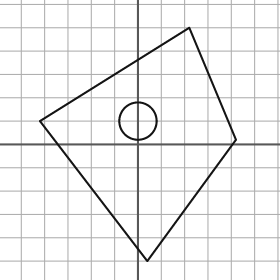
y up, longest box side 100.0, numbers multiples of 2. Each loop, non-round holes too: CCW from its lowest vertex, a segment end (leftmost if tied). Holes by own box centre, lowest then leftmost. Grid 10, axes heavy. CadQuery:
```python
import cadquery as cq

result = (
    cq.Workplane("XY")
    .moveTo(4.0, -50.0)
    .lineTo(42.0, 2.0)
    .lineTo(22.0, 50.0)
    .lineTo(-42.0, 10.0)
    .close()
    .moveTo(0.0, 10.0)
    .circle(8.0)
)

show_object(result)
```